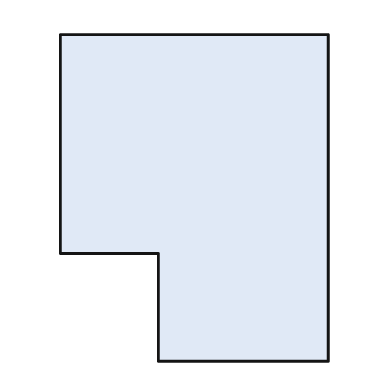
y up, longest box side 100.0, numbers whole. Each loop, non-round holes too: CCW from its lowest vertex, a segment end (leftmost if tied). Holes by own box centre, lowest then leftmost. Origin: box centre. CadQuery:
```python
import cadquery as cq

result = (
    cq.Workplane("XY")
    .moveTo(-11.0, -50.0)
    .lineTo(41.0, -50.0)
    .lineTo(41.0, 50.0)
    .lineTo(-41.0, 50.0)
    .lineTo(-41.0, -17.0)
    .lineTo(-11.0, -17.0)
    .close()
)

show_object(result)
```